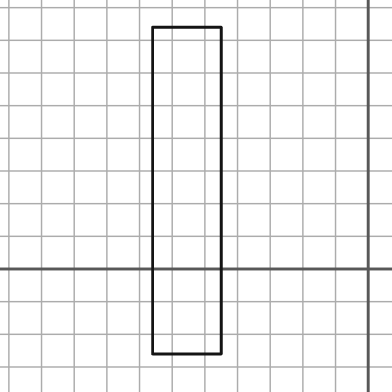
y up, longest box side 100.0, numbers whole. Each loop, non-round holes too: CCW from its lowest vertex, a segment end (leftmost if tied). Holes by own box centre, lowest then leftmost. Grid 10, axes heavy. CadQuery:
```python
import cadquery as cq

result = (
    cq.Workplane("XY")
    .moveTo(-66.0, -26.0)
    .lineTo(-45.0, -26.0)
    .lineTo(-45.0, 74.0)
    .lineTo(-66.0, 74.0)
    .close()
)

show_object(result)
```